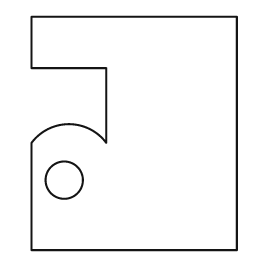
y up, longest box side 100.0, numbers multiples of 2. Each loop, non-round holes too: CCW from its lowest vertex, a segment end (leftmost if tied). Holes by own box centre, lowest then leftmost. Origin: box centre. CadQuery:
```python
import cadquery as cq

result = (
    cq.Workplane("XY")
    .moveTo(-44.0, -50.0)
    .lineTo(44.0, -50.0)
    .lineTo(44.0, 50.0)
    .lineTo(-44.0, 50.0)
    .lineTo(-44.0, 28.0)
    .lineTo(-12.0, 28.0)
    .lineTo(-12.0, -4.0)
    .threePointArc((-28.0, 4.0), (-44.0, -4.0))
    .close()
    .moveTo(-30.0, -20.0)
    .circle(8.0)
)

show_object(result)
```